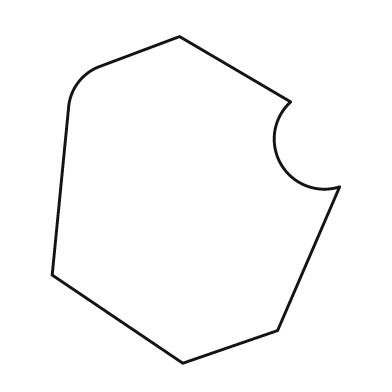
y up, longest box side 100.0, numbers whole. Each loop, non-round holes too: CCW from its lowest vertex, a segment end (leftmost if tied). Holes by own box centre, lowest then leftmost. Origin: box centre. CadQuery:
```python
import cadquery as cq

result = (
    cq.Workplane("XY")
    .moveTo(-4.0, -50.0)
    .lineTo(25.0, -40.0)
    .lineTo(44.0, 4.0)
    .threePointArc((26.0, 11.0), (29.0, 30.0))
    .lineTo(-5.0, 50.0)
    .lineTo(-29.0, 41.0)
    .threePointArc((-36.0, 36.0), (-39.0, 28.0))
    .lineTo(-44.0, -23.0)
    .close()
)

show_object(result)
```